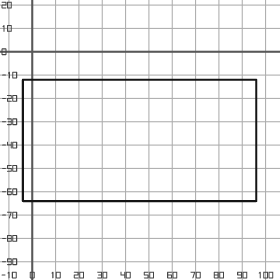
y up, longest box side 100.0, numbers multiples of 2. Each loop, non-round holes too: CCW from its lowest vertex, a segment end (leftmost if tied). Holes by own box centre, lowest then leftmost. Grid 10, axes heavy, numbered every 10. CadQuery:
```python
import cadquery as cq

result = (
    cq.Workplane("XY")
    .moveTo(-4.0, -64.0)
    .lineTo(96.0, -64.0)
    .lineTo(96.0, -12.0)
    .lineTo(-4.0, -12.0)
    .close()
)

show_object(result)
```